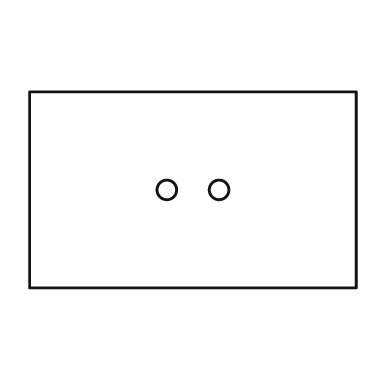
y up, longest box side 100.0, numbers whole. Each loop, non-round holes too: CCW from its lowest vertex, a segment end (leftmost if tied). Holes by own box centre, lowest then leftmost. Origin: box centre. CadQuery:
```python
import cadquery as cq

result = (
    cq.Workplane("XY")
    .moveTo(-50.0, -30.0)
    .lineTo(50.0, -30.0)
    .lineTo(50.0, 30.0)
    .lineTo(-50.0, 30.0)
    .close()
    .moveTo(-8.0, 0.0)
    .circle(3.0)
    .moveTo(8.0, 0.0)
    .circle(3.0)
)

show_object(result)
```